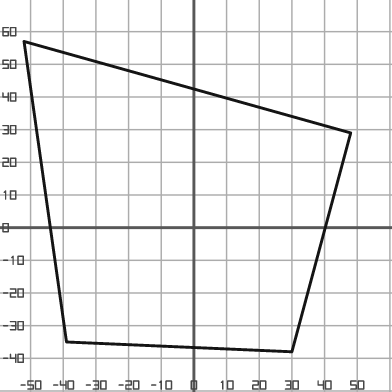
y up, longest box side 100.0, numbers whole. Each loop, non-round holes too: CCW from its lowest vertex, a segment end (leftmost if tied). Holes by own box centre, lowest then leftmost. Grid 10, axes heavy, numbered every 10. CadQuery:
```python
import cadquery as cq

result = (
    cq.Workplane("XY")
    .moveTo(30.0, -38.0)
    .lineTo(48.0, 29.0)
    .lineTo(-52.0, 57.0)
    .lineTo(-39.0, -35.0)
    .close()
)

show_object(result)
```